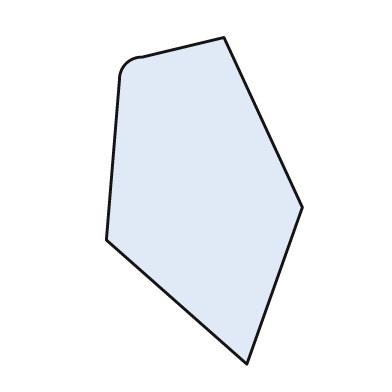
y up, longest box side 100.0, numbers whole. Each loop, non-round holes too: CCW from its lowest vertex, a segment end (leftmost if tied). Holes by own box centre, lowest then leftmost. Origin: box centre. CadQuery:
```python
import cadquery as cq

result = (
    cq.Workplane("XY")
    .moveTo(13.0, -50.0)
    .lineTo(30.0, -2.0)
    .lineTo(6.0, 50.0)
    .lineTo(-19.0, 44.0)
    .threePointArc((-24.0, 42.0), (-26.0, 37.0))
    .lineTo(-30.0, -12.0)
    .close()
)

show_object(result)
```